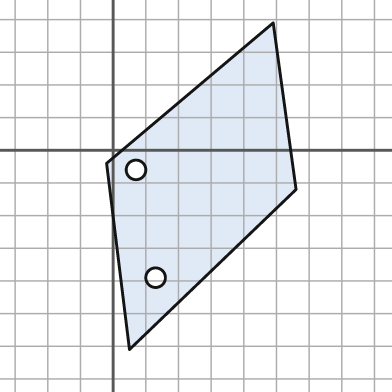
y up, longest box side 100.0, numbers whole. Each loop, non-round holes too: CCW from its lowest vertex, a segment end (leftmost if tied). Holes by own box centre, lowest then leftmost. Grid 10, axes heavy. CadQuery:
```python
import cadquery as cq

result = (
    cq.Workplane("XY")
    .moveTo(5.0, -61.0)
    .lineTo(56.0, -12.0)
    .lineTo(49.0, 39.0)
    .lineTo(-2.0, -4.0)
    .close()
    .moveTo(13.0, -39.0)
    .circle(3.0)
    .moveTo(7.0, -6.0)
    .circle(3.0)
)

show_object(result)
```